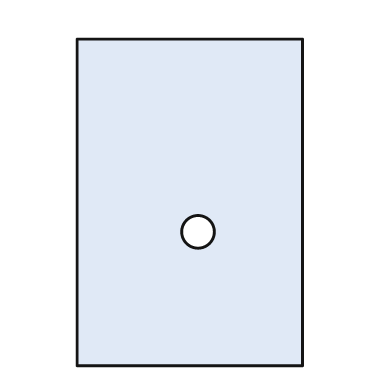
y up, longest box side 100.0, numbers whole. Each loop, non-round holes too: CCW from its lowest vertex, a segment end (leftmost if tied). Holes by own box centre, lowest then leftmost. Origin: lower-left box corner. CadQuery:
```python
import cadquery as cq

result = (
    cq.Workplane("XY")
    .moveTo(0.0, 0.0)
    .lineTo(69.0, 0.0)
    .lineTo(69.0, 100.0)
    .lineTo(0.0, 100.0)
    .close()
    .moveTo(37.0, 41.0)
    .circle(5.0)
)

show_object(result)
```